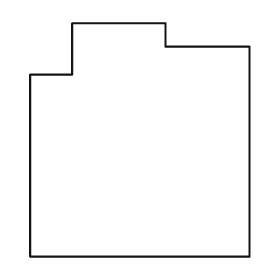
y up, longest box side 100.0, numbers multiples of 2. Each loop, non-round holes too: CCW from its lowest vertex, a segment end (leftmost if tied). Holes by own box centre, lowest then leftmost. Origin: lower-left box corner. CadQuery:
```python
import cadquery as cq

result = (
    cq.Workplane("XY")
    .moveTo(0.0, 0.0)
    .lineTo(94.0, 0.0)
    .lineTo(94.0, 90.0)
    .lineTo(58.0, 90.0)
    .lineTo(58.0, 100.0)
    .lineTo(18.0, 100.0)
    .lineTo(18.0, 78.0)
    .lineTo(0.0, 78.0)
    .close()
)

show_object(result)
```